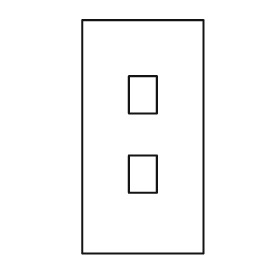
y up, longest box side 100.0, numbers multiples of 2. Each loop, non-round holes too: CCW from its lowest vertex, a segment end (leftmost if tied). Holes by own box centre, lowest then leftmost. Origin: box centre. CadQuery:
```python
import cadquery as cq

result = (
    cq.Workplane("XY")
    .moveTo(-26.0, -50.0)
    .lineTo(26.0, -50.0)
    .lineTo(26.0, 50.0)
    .lineTo(-26.0, 50.0)
    .close()
    .moveTo(-6.0, -24.0)
    .lineTo(6.0, -24.0)
    .lineTo(6.0, -8.0)
    .lineTo(-6.0, -8.0)
    .close()
    .moveTo(-6.0, 10.0)
    .lineTo(6.0, 10.0)
    .lineTo(6.0, 26.0)
    .lineTo(-6.0, 26.0)
    .close()
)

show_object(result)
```